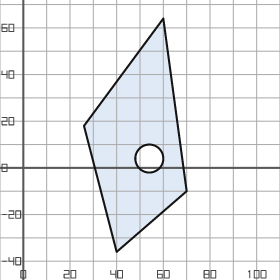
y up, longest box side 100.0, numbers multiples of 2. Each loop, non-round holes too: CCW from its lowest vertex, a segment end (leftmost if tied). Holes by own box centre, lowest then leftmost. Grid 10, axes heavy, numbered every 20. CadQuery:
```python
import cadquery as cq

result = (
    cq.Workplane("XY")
    .moveTo(40.0, -36.0)
    .lineTo(70.0, -10.0)
    .lineTo(60.0, 64.0)
    .lineTo(26.0, 18.0)
    .close()
    .moveTo(54.0, 4.0)
    .circle(6.0)
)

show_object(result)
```